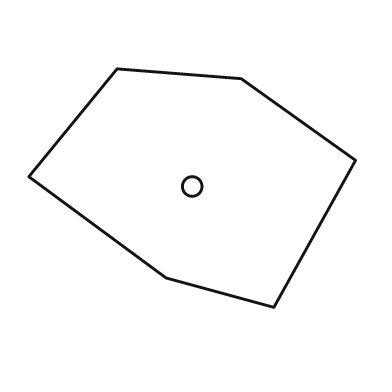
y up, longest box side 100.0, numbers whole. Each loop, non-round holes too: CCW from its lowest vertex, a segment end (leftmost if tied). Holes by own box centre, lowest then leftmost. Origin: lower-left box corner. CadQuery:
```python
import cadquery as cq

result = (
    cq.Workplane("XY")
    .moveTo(75.0, 0.0)
    .lineTo(100.0, 45.0)
    .lineTo(65.0, 70.0)
    .lineTo(27.0, 73.0)
    .lineTo(0.0, 40.0)
    .lineTo(42.0, 9.0)
    .close()
    .moveTo(50.0, 37.0)
    .circle(3.0)
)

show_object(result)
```